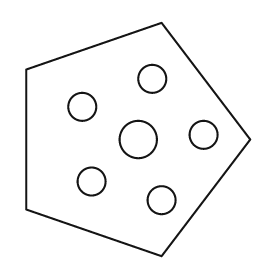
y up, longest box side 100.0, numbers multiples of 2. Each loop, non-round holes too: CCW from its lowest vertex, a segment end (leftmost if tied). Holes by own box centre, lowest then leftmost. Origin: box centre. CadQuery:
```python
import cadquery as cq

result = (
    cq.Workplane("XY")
    .moveTo(10.0, -50.0)
    .lineTo(48.0, 0.0)
    .lineTo(10.0, 50.0)
    .lineTo(-48.0, 30.0)
    .lineTo(-48.0, -30.0)
    .close()
    .moveTo(10.0, -26.0)
    .circle(6.0)
    .moveTo(-20.0, -18.0)
    .circle(6.0)
    .moveTo(0.0, 0.0)
    .circle(8.0)
    .moveTo(28.0, 2.0)
    .circle(6.0)
    .moveTo(-24.0, 14.0)
    .circle(6.0)
    .moveTo(6.0, 26.0)
    .circle(6.0)
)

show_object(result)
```